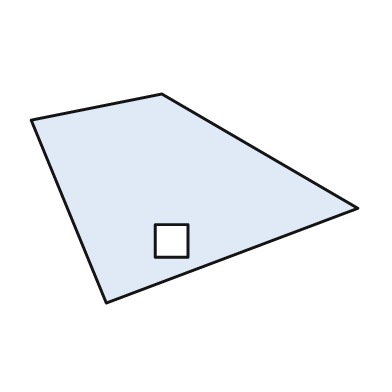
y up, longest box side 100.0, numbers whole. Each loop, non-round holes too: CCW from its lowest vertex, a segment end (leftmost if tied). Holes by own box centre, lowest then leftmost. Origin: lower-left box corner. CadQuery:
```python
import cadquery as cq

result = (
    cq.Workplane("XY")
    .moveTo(23.0, 0.0)
    .lineTo(100.0, 29.0)
    .lineTo(40.0, 64.0)
    .lineTo(0.0, 56.0)
    .close()
    .moveTo(38.0, 14.0)
    .lineTo(48.0, 14.0)
    .lineTo(48.0, 24.0)
    .lineTo(38.0, 24.0)
    .close()
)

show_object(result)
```